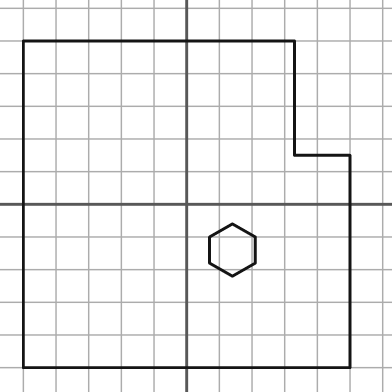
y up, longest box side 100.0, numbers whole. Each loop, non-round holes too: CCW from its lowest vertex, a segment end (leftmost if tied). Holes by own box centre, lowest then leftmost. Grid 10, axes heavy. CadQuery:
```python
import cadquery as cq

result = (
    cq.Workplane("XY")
    .moveTo(-50.0, -50.0)
    .lineTo(50.0, -50.0)
    .lineTo(50.0, 15.0)
    .lineTo(33.0, 15.0)
    .lineTo(33.0, 50.0)
    .lineTo(-50.0, 50.0)
    .close()
    .moveTo(14.0, -22.0)
    .lineTo(21.0, -18.0)
    .lineTo(21.0, -10.0)
    .lineTo(14.0, -6.0)
    .lineTo(7.0, -10.0)
    .lineTo(7.0, -18.0)
    .close()
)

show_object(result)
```